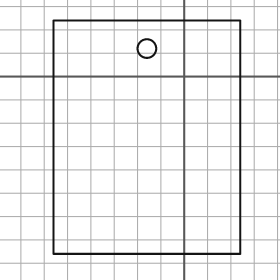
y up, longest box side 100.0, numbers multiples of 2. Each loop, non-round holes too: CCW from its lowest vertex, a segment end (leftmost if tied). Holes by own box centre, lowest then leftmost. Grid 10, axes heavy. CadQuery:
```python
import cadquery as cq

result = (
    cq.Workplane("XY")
    .moveTo(-56.0, -76.0)
    .lineTo(24.0, -76.0)
    .lineTo(24.0, 24.0)
    .lineTo(-56.0, 24.0)
    .close()
    .moveTo(-16.0, 12.0)
    .circle(4.0)
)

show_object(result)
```